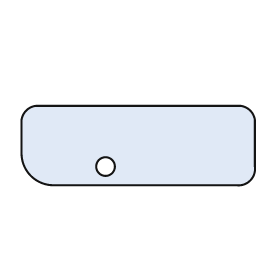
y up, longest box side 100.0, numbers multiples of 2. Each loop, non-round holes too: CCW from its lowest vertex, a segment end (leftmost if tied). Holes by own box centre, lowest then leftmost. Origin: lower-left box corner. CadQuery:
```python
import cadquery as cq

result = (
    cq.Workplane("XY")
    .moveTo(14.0, 0.0)
    .lineTo(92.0, 0.0)
    .threePointArc((98.0, 2.0), (100.0, 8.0))
    .lineTo(100.0, 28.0)
    .threePointArc((98.0, 32.0), (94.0, 34.0))
    .lineTo(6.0, 34.0)
    .threePointArc((2.0, 32.0), (0.0, 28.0))
    .lineTo(0.0, 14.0)
    .threePointArc((4.0, 4.0), (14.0, 0.0))
    .close()
    .moveTo(36.0, 8.0)
    .circle(4.0)
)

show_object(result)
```